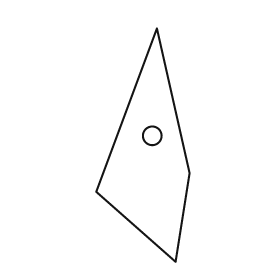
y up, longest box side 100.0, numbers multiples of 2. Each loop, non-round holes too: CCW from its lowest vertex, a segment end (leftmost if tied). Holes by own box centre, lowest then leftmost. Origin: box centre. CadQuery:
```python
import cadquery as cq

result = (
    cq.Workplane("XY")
    .moveTo(14.0, -50.0)
    .lineTo(20.0, -12.0)
    .lineTo(6.0, 50.0)
    .lineTo(-20.0, -20.0)
    .close()
    .moveTo(4.0, 4.0)
    .circle(4.0)
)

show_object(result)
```